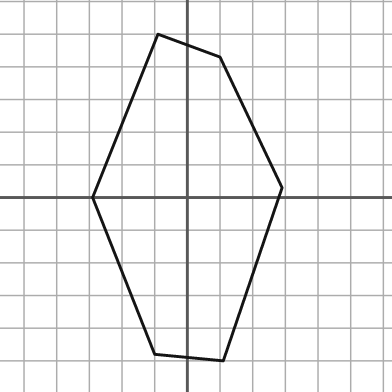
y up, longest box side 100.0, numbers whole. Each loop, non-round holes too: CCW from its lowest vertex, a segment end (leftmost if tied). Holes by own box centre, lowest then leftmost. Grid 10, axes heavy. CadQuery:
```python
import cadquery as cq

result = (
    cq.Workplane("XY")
    .moveTo(11.0, -50.0)
    .lineTo(29.0, 3.0)
    .lineTo(10.0, 43.0)
    .lineTo(-9.0, 50.0)
    .lineTo(-29.0, 0.0)
    .lineTo(-10.0, -48.0)
    .close()
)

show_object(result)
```